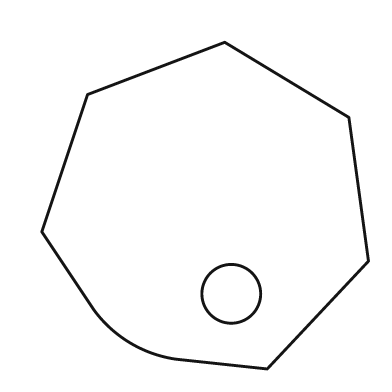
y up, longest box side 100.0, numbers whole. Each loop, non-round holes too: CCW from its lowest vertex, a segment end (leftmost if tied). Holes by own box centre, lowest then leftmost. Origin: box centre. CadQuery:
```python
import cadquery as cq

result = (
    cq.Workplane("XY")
    .moveTo(19.0, -50.0)
    .lineTo(50.0, -17.0)
    .lineTo(44.0, 27.0)
    .lineTo(6.0, 50.0)
    .lineTo(-36.0, 34.0)
    .lineTo(-50.0, -8.0)
    .lineTo(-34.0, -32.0)
    .threePointArc((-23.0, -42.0), (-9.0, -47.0))
    .close()
    .moveTo(8.0, -27.0)
    .circle(9.0)
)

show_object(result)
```